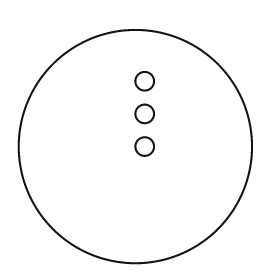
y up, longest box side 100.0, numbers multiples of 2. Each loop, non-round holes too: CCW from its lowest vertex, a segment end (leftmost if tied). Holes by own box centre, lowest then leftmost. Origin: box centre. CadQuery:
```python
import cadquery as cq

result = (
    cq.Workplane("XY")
    .moveTo(0.0, 0.0)
    .circle(50.0)
    .moveTo(4.0, 0.0)
    .circle(4.0)
    .moveTo(4.0, 14.0)
    .circle(4.0)
    .moveTo(4.0, 28.0)
    .circle(4.0)
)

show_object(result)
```